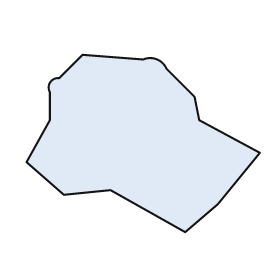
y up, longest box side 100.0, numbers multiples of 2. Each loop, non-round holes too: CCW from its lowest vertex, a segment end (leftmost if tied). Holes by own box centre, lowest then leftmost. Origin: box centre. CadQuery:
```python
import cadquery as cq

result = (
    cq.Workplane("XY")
    .moveTo(18.0, -38.0)
    .lineTo(32.0, -26.0)
    .lineTo(50.0, -4.0)
    .lineTo(24.0, 10.0)
    .lineTo(22.0, 20.0)
    .lineTo(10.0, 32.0)
    .threePointArc((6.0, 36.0), (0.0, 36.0))
    .lineTo(-26.0, 38.0)
    .lineTo(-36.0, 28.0)
    .threePointArc((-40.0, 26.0), (-40.0, 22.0))
    .lineTo(-40.0, 10.0)
    .lineTo(-50.0, -8.0)
    .lineTo(-34.0, -22.0)
    .lineTo(-14.0, -20.0)
    .close()
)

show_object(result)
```